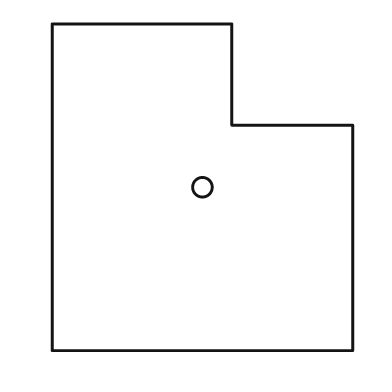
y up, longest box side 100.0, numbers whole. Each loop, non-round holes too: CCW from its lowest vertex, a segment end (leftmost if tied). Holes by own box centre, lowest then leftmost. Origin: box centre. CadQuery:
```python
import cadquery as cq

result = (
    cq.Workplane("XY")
    .moveTo(-46.0, -50.0)
    .lineTo(46.0, -50.0)
    .lineTo(46.0, 19.0)
    .lineTo(9.0, 19.0)
    .lineTo(9.0, 50.0)
    .lineTo(-46.0, 50.0)
    .close()
    .moveTo(0.0, 0.0)
    .circle(3.0)
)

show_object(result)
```